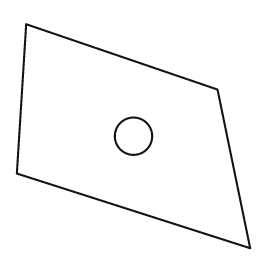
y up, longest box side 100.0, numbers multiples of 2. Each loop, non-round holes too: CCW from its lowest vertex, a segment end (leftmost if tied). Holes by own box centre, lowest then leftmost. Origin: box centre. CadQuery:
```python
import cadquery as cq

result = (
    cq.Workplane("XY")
    .moveTo(50.0, -48.0)
    .lineTo(36.0, 20.0)
    .lineTo(-46.0, 48.0)
    .lineTo(-50.0, -16.0)
    .close()
    .moveTo(0.0, 0.0)
    .circle(8.0)
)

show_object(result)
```